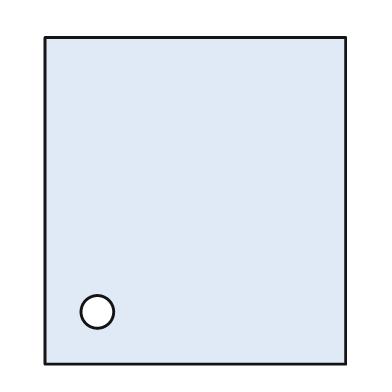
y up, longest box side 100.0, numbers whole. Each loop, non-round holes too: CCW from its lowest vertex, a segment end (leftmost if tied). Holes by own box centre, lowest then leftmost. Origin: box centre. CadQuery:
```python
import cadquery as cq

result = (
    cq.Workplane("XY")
    .moveTo(-46.0, -50.0)
    .lineTo(46.0, -50.0)
    .lineTo(46.0, 50.0)
    .lineTo(-46.0, 50.0)
    .close()
    .moveTo(-30.0, -34.0)
    .circle(5.0)
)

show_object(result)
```